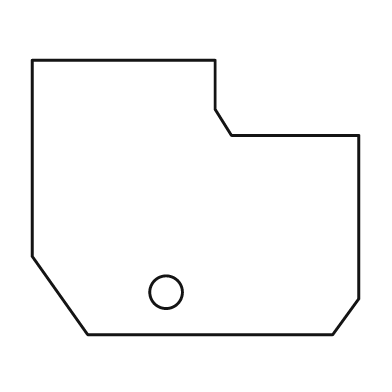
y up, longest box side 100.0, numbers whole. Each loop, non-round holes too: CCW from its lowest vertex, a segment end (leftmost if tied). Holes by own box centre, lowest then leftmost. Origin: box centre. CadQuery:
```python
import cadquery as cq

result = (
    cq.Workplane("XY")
    .moveTo(-33.0, -42.0)
    .lineTo(42.0, -42.0)
    .lineTo(50.0, -31.0)
    .lineTo(50.0, 19.0)
    .lineTo(11.0, 19.0)
    .lineTo(6.0, 27.0)
    .lineTo(6.0, 42.0)
    .lineTo(-50.0, 42.0)
    .lineTo(-50.0, -18.0)
    .close()
    .moveTo(-9.0, -29.0)
    .circle(5.0)
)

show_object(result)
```